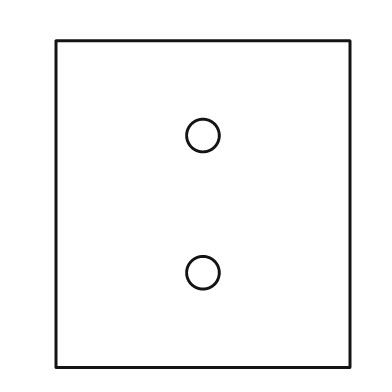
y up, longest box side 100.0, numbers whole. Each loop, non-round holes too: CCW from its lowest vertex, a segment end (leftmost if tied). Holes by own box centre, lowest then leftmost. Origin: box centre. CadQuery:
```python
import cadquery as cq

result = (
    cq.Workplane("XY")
    .moveTo(-45.0, -50.0)
    .lineTo(45.0, -50.0)
    .lineTo(45.0, 50.0)
    .lineTo(-45.0, 50.0)
    .close()
    .moveTo(0.0, -21.0)
    .circle(5.0)
    .moveTo(0.0, 21.0)
    .circle(5.0)
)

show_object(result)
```